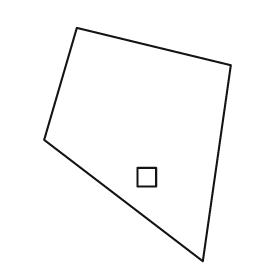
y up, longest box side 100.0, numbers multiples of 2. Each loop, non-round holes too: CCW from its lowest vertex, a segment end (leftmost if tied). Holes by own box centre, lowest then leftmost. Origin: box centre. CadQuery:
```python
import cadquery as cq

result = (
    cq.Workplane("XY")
    .moveTo(28.0, -50.0)
    .lineTo(40.0, 34.0)
    .lineTo(-26.0, 50.0)
    .lineTo(-40.0, 2.0)
    .close()
    .moveTo(0.0, -18.0)
    .lineTo(8.0, -18.0)
    .lineTo(8.0, -10.0)
    .lineTo(0.0, -10.0)
    .close()
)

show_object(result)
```